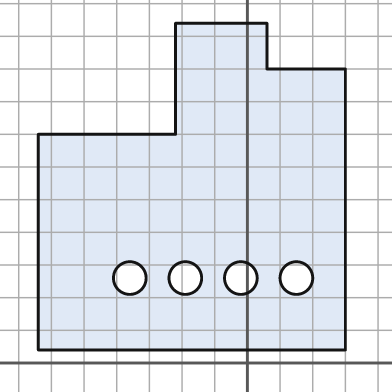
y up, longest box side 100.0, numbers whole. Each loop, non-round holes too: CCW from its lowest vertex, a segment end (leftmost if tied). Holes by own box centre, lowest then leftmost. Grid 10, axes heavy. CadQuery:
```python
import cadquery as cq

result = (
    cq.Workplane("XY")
    .moveTo(-64.0, 4.0)
    .lineTo(30.0, 4.0)
    .lineTo(30.0, 90.0)
    .lineTo(6.0, 90.0)
    .lineTo(6.0, 104.0)
    .lineTo(-22.0, 104.0)
    .lineTo(-22.0, 70.0)
    .lineTo(-64.0, 70.0)
    .close()
    .moveTo(-36.0, 26.0)
    .circle(5.0)
    .moveTo(-19.0, 26.0)
    .circle(5.0)
    .moveTo(-2.0, 26.0)
    .circle(5.0)
    .moveTo(15.0, 26.0)
    .circle(5.0)
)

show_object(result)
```